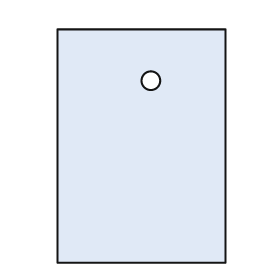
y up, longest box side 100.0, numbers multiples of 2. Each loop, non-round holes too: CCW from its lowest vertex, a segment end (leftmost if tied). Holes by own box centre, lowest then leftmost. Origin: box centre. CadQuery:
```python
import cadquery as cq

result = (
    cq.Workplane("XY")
    .moveTo(-36.0, -50.0)
    .lineTo(36.0, -50.0)
    .lineTo(36.0, 50.0)
    .lineTo(-36.0, 50.0)
    .close()
    .moveTo(4.0, 28.0)
    .circle(4.0)
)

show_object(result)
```